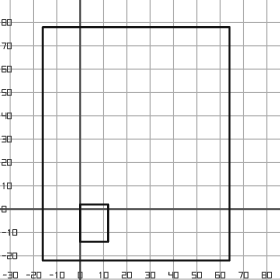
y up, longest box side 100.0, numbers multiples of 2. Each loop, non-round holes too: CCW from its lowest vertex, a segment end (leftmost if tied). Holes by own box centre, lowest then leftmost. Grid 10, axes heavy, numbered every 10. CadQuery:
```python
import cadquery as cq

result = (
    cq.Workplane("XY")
    .moveTo(-16.0, -22.0)
    .lineTo(64.0, -22.0)
    .lineTo(64.0, 78.0)
    .lineTo(-16.0, 78.0)
    .close()
    .moveTo(0.0, -14.0)
    .lineTo(12.0, -14.0)
    .lineTo(12.0, 2.0)
    .lineTo(0.0, 2.0)
    .close()
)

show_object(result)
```